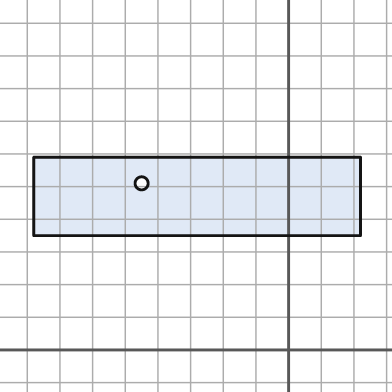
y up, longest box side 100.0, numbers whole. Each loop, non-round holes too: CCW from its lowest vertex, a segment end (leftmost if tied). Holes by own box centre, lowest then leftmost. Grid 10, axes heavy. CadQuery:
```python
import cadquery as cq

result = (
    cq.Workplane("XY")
    .moveTo(-78.0, 35.0)
    .lineTo(22.0, 35.0)
    .lineTo(22.0, 59.0)
    .lineTo(-78.0, 59.0)
    .close()
    .moveTo(-45.0, 51.0)
    .circle(2.0)
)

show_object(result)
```